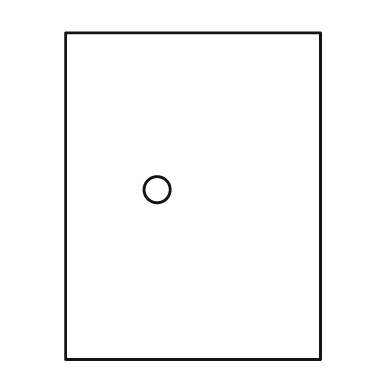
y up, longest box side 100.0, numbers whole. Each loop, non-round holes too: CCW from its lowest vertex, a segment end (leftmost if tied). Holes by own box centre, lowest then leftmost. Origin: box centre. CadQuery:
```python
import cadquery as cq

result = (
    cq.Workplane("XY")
    .moveTo(-39.0, -50.0)
    .lineTo(39.0, -50.0)
    .lineTo(39.0, 50.0)
    .lineTo(-39.0, 50.0)
    .close()
    .moveTo(-11.0, 2.0)
    .circle(4.0)
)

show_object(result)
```